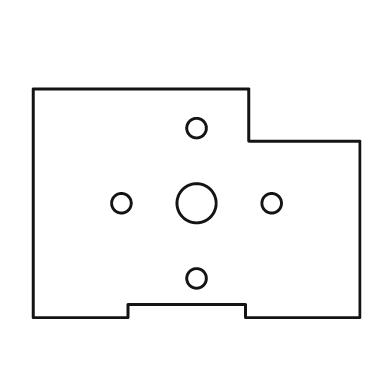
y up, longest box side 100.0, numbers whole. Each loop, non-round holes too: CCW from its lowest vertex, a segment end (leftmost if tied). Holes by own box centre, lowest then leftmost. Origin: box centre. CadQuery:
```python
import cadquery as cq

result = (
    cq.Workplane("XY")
    .moveTo(-50.0, -35.0)
    .lineTo(-21.0, -35.0)
    .lineTo(-21.0, -31.0)
    .lineTo(15.0, -31.0)
    .lineTo(15.0, -35.0)
    .lineTo(50.0, -35.0)
    .lineTo(50.0, 19.0)
    .lineTo(16.0, 19.0)
    .lineTo(16.0, 35.0)
    .lineTo(-50.0, 35.0)
    .close()
    .moveTo(0.0, -23.0)
    .circle(3.0)
    .moveTo(-23.0, 0.0)
    .circle(3.0)
    .moveTo(0.0, 0.0)
    .circle(6.0)
    .moveTo(23.0, 0.0)
    .circle(3.0)
    .moveTo(0.0, 23.0)
    .circle(3.0)
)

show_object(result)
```